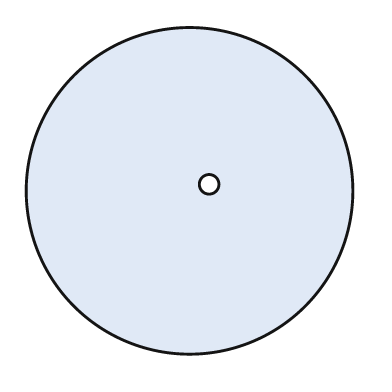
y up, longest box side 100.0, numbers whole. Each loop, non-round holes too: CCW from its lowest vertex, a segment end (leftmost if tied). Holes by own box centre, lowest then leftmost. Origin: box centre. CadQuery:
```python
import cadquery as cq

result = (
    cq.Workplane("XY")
    .moveTo(0.0, 0.0)
    .circle(50.0)
    .moveTo(6.0, 2.0)
    .circle(3.0)
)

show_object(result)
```